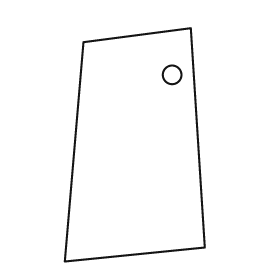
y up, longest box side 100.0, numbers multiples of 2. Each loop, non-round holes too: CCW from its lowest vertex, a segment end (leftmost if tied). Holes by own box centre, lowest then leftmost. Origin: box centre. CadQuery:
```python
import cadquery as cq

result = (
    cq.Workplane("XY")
    .moveTo(-30.0, -50.0)
    .lineTo(30.0, -44.0)
    .lineTo(24.0, 50.0)
    .lineTo(-22.0, 44.0)
    .close()
    .moveTo(16.0, 30.0)
    .circle(4.0)
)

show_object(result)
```